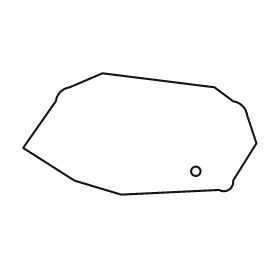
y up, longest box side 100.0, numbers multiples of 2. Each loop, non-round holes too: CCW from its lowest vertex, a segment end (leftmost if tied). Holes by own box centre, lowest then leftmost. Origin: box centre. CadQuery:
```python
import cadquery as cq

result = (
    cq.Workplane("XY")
    .moveTo(-8.0, -26.0)
    .lineTo(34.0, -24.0)
    .threePointArc((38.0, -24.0), (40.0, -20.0))
    .lineTo(50.0, -4.0)
    .lineTo(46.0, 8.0)
    .threePointArc((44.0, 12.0), (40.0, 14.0))
    .lineTo(32.0, 20.0)
    .lineTo(-16.0, 26.0)
    .lineTo(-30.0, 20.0)
    .threePointArc((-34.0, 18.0), (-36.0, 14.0))
    .lineTo(-50.0, -6.0)
    .lineTo(-28.0, -20.0)
    .close()
    .moveTo(24.0, -16.0)
    .circle(2.0)
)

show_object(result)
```